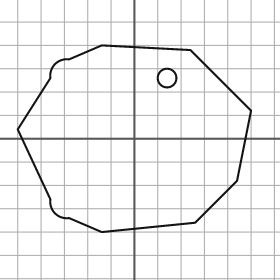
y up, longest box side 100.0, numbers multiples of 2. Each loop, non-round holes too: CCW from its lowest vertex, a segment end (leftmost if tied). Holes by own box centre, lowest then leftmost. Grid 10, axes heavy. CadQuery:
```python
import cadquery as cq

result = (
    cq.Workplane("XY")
    .moveTo(-14.0, -40.0)
    .lineTo(26.0, -36.0)
    .lineTo(44.0, -18.0)
    .lineTo(50.0, 12.0)
    .lineTo(24.0, 38.0)
    .lineTo(-14.0, 40.0)
    .lineTo(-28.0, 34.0)
    .threePointArc((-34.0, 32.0), (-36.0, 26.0))
    .lineTo(-50.0, 4.0)
    .lineTo(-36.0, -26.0)
    .threePointArc((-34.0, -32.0), (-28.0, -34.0))
    .close()
    .moveTo(14.0, 26.0)
    .circle(4.0)
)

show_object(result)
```